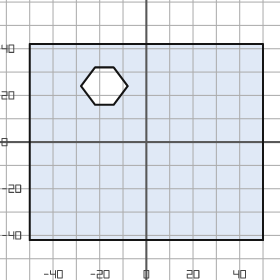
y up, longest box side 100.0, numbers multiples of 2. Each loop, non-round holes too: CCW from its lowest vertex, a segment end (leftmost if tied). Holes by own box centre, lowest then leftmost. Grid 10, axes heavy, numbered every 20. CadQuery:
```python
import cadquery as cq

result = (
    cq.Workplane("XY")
    .moveTo(-50.0, -42.0)
    .lineTo(50.0, -42.0)
    .lineTo(50.0, 42.0)
    .lineTo(-50.0, 42.0)
    .close()
    .moveTo(-22.0, 16.0)
    .lineTo(-14.0, 16.0)
    .lineTo(-8.0, 24.0)
    .lineTo(-14.0, 32.0)
    .lineTo(-22.0, 32.0)
    .lineTo(-28.0, 24.0)
    .close()
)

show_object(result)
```